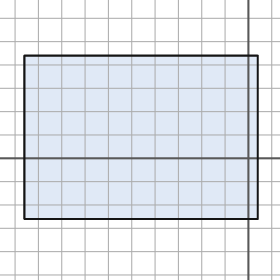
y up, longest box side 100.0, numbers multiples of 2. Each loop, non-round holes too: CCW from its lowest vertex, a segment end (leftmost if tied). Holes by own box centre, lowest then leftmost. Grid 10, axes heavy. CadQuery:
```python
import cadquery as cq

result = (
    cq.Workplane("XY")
    .moveTo(-96.0, -26.0)
    .lineTo(4.0, -26.0)
    .lineTo(4.0, 44.0)
    .lineTo(-96.0, 44.0)
    .close()
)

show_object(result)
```